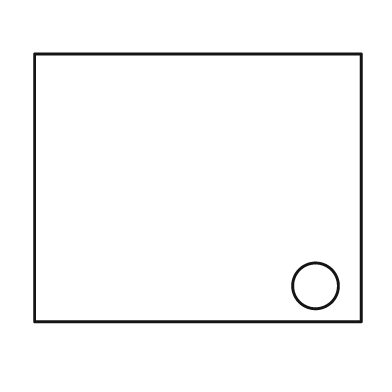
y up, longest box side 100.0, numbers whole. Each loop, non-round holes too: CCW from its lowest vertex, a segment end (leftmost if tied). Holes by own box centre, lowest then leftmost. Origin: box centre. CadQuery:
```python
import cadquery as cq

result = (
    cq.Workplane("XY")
    .moveTo(-50.0, -41.0)
    .lineTo(50.0, -41.0)
    .lineTo(50.0, 41.0)
    .lineTo(-50.0, 41.0)
    .close()
    .moveTo(36.0, -30.0)
    .circle(7.0)
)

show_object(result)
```